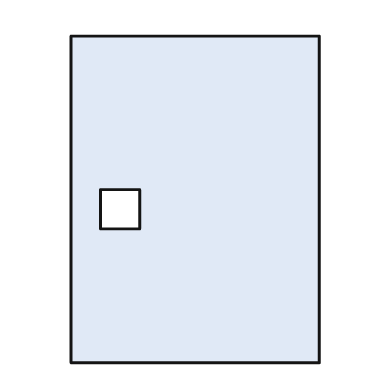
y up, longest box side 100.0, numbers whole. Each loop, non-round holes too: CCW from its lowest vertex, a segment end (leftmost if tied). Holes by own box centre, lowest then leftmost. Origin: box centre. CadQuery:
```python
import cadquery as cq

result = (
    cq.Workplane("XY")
    .moveTo(-38.0, -50.0)
    .lineTo(38.0, -50.0)
    .lineTo(38.0, 50.0)
    .lineTo(-38.0, 50.0)
    .close()
    .moveTo(-29.0, -9.0)
    .lineTo(-17.0, -9.0)
    .lineTo(-17.0, 3.0)
    .lineTo(-29.0, 3.0)
    .close()
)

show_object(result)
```